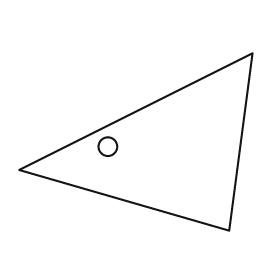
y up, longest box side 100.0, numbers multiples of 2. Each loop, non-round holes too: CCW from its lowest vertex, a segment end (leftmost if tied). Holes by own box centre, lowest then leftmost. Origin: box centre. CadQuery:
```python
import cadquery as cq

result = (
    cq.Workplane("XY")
    .moveTo(40.0, -38.0)
    .lineTo(50.0, 38.0)
    .lineTo(-50.0, -12.0)
    .close()
    .moveTo(-12.0, -2.0)
    .circle(4.0)
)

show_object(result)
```